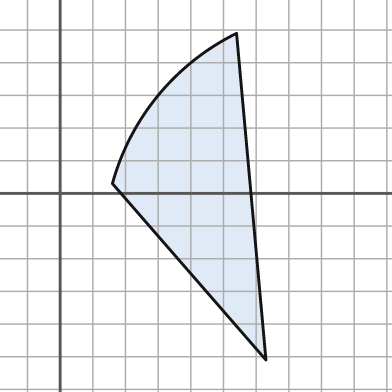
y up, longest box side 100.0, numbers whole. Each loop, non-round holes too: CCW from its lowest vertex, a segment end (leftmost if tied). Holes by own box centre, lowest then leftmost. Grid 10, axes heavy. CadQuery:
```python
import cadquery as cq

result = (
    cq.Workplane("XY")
    .moveTo(63.0, -51.0)
    .lineTo(54.0, 49.0)
    .threePointArc((30.0, 30.0), (16.0, 3.0))
    .close()
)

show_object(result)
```